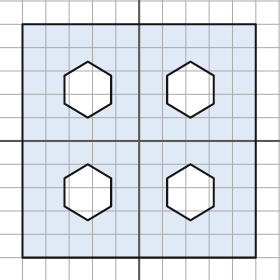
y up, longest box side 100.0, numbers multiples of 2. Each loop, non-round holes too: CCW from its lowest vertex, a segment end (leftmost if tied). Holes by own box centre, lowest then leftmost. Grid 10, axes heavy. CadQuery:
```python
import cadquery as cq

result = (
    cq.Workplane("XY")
    .moveTo(-50.0, -50.0)
    .lineTo(50.0, -50.0)
    .lineTo(50.0, 50.0)
    .lineTo(-50.0, 50.0)
    .close()
    .moveTo(-22.0, -34.0)
    .lineTo(-12.0, -28.0)
    .lineTo(-12.0, -16.0)
    .lineTo(-22.0, -10.0)
    .lineTo(-32.0, -16.0)
    .lineTo(-32.0, -28.0)
    .close()
    .moveTo(22.0, -34.0)
    .lineTo(32.0, -28.0)
    .lineTo(32.0, -16.0)
    .lineTo(22.0, -10.0)
    .lineTo(12.0, -16.0)
    .lineTo(12.0, -28.0)
    .close()
    .moveTo(-22.0, 10.0)
    .lineTo(-12.0, 16.0)
    .lineTo(-12.0, 28.0)
    .lineTo(-22.0, 34.0)
    .lineTo(-32.0, 28.0)
    .lineTo(-32.0, 16.0)
    .close()
    .moveTo(22.0, 10.0)
    .lineTo(32.0, 16.0)
    .lineTo(32.0, 28.0)
    .lineTo(22.0, 34.0)
    .lineTo(12.0, 28.0)
    .lineTo(12.0, 16.0)
    .close()
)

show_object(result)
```